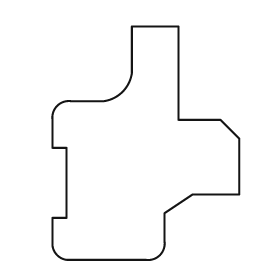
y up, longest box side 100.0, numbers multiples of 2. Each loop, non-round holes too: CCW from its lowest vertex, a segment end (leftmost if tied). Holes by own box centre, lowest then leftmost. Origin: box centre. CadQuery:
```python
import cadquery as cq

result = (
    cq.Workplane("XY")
    .moveTo(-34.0, -50.0)
    .lineTo(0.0, -50.0)
    .threePointArc((6.0, -48.0), (8.0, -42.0))
    .lineTo(8.0, -30.0)
    .lineTo(20.0, -22.0)
    .lineTo(40.0, -22.0)
    .lineTo(40.0, 2.0)
    .lineTo(32.0, 10.0)
    .lineTo(14.0, 10.0)
    .lineTo(14.0, 50.0)
    .lineTo(-6.0, 50.0)
    .lineTo(-6.0, 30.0)
    .threePointArc((-10.0, 22.0), (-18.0, 18.0))
    .lineTo(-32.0, 18.0)
    .threePointArc((-38.0, 16.0), (-40.0, 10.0))
    .lineTo(-40.0, -2.0)
    .lineTo(-34.0, -2.0)
    .lineTo(-34.0, -32.0)
    .lineTo(-40.0, -32.0)
    .lineTo(-40.0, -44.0)
    .threePointArc((-38.0, -48.0), (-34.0, -50.0))
    .close()
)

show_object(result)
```